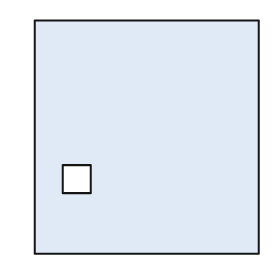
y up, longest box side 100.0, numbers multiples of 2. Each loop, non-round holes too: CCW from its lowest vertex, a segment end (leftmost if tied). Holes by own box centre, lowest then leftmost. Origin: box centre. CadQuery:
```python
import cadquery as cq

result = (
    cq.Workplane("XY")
    .moveTo(-48.0, -50.0)
    .lineTo(48.0, -50.0)
    .lineTo(48.0, 50.0)
    .lineTo(-48.0, 50.0)
    .close()
    .moveTo(-36.0, -24.0)
    .lineTo(-24.0, -24.0)
    .lineTo(-24.0, -12.0)
    .lineTo(-36.0, -12.0)
    .close()
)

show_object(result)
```